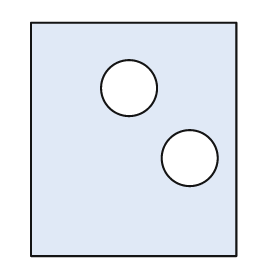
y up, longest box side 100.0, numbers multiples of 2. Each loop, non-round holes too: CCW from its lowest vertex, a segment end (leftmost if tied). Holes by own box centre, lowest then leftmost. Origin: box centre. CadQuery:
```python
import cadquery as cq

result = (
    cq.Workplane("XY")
    .moveTo(-44.0, -50.0)
    .lineTo(44.0, -50.0)
    .lineTo(44.0, 50.0)
    .lineTo(-44.0, 50.0)
    .close()
    .moveTo(24.0, -8.0)
    .circle(12.0)
    .moveTo(-2.0, 22.0)
    .circle(12.0)
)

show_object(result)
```